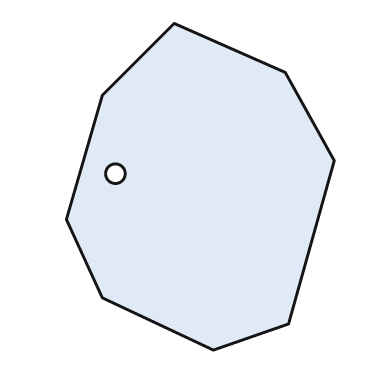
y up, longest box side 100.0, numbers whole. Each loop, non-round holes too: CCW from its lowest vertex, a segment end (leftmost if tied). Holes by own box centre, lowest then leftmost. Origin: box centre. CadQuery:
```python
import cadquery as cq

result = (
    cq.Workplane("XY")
    .moveTo(4.0, -50.0)
    .lineTo(27.0, -42.0)
    .lineTo(41.0, 8.0)
    .lineTo(26.0, 35.0)
    .lineTo(-8.0, 50.0)
    .lineTo(-30.0, 28.0)
    .lineTo(-41.0, -10.0)
    .lineTo(-30.0, -34.0)
    .close()
    .moveTo(-26.0, 4.0)
    .circle(3.0)
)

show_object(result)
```